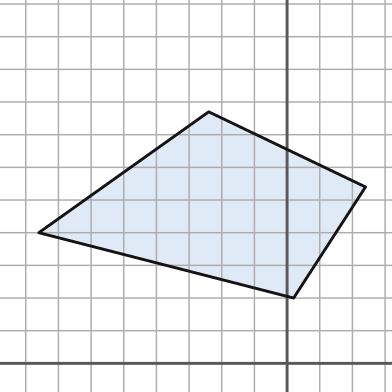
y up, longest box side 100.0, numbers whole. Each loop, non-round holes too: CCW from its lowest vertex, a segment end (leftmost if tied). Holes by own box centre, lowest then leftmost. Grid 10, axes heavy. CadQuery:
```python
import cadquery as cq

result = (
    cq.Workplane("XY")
    .moveTo(2.0, 20.0)
    .lineTo(24.0, 54.0)
    .lineTo(-24.0, 77.0)
    .lineTo(-76.0, 40.0)
    .close()
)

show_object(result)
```